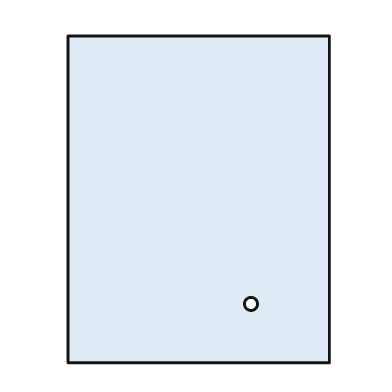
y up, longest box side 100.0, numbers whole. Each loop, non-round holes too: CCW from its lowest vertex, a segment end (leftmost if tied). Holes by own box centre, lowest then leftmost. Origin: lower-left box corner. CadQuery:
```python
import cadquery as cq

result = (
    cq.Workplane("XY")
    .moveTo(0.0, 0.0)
    .lineTo(80.0, 0.0)
    .lineTo(80.0, 100.0)
    .lineTo(0.0, 100.0)
    .close()
    .moveTo(56.0, 18.0)
    .circle(2.0)
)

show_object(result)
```